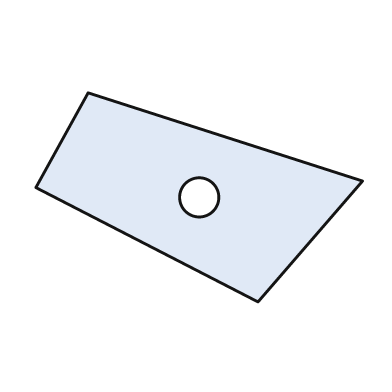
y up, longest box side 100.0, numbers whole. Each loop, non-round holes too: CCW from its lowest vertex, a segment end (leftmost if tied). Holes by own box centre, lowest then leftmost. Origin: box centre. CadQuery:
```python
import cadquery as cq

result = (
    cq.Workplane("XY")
    .moveTo(18.0, -32.0)
    .lineTo(50.0, 5.0)
    .lineTo(-34.0, 32.0)
    .lineTo(-50.0, 3.0)
    .close()
    .moveTo(0.0, 0.0)
    .circle(6.0)
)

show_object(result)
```